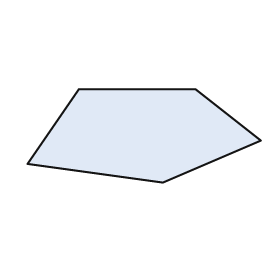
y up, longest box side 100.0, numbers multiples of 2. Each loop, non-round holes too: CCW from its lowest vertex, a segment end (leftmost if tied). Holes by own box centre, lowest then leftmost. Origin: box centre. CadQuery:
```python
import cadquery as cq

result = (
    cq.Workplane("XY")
    .moveTo(8.0, -20.0)
    .lineTo(50.0, -2.0)
    .lineTo(22.0, 20.0)
    .lineTo(-28.0, 20.0)
    .lineTo(-50.0, -12.0)
    .close()
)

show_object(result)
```